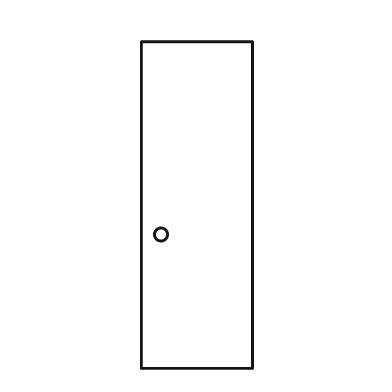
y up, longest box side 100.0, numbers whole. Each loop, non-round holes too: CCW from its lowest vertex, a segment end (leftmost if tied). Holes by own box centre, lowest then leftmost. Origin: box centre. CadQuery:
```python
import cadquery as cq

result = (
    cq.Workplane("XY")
    .moveTo(-17.0, -50.0)
    .lineTo(17.0, -50.0)
    .lineTo(17.0, 50.0)
    .lineTo(-17.0, 50.0)
    .close()
    .moveTo(-11.0, -9.0)
    .circle(2.0)
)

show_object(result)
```